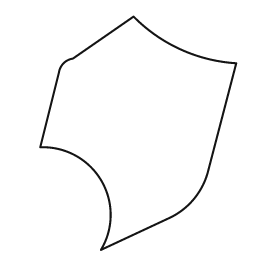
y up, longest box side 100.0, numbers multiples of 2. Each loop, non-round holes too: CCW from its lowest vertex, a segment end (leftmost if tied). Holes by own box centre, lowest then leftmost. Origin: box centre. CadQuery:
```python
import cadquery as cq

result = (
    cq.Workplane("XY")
    .moveTo(-16.0, -50.0)
    .lineTo(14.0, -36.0)
    .threePointArc((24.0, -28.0), (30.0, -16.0))
    .lineTo(42.0, 30.0)
    .threePointArc((18.0, 36.0), (-2.0, 50.0))
    .lineTo(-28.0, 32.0)
    .threePointArc((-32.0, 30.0), (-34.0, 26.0))
    .lineTo(-42.0, -6.0)
    .threePointArc((-16.0, -20.0), (-16.0, -50.0))
    .close()
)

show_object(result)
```